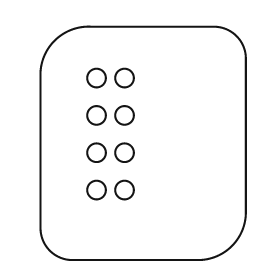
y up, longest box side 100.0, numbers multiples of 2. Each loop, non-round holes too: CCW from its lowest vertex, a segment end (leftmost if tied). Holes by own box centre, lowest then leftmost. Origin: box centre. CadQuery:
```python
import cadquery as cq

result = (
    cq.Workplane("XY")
    .moveTo(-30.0, -50.0)
    .lineTo(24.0, -50.0)
    .threePointArc((38.0, -44.0), (44.0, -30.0))
    .lineTo(44.0, 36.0)
    .threePointArc((40.0, 46.0), (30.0, 50.0))
    .lineTo(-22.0, 50.0)
    .threePointArc((-38.0, 44.0), (-44.0, 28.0))
    .lineTo(-44.0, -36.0)
    .threePointArc((-40.0, -46.0), (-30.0, -50.0))
    .close()
    .moveTo(-20.0, -20.0)
    .circle(4.0)
    .moveTo(-8.0, -20.0)
    .circle(4.0)
    .moveTo(-20.0, -4.0)
    .circle(4.0)
    .moveTo(-8.0, -4.0)
    .circle(4.0)
    .moveTo(-20.0, 12.0)
    .circle(4.0)
    .moveTo(-8.0, 12.0)
    .circle(4.0)
    .moveTo(-20.0, 28.0)
    .circle(4.0)
    .moveTo(-8.0, 28.0)
    .circle(4.0)
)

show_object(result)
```